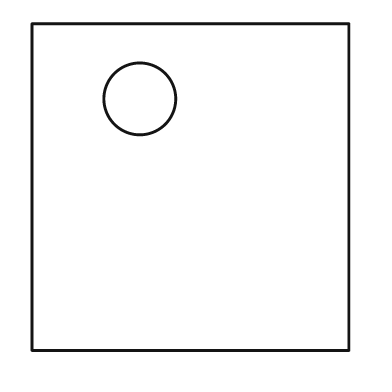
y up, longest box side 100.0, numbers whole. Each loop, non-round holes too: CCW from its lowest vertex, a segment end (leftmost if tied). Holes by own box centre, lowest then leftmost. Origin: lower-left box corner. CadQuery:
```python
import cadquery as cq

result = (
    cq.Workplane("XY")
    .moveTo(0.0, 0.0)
    .lineTo(97.0, 0.0)
    .lineTo(97.0, 100.0)
    .lineTo(0.0, 100.0)
    .close()
    .moveTo(33.0, 77.0)
    .circle(11.0)
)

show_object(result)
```